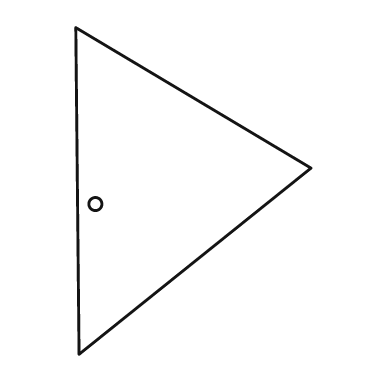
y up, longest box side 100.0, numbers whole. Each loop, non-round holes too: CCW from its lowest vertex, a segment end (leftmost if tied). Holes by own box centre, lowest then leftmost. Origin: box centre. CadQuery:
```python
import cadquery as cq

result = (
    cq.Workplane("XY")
    .moveTo(-35.0, -50.0)
    .lineTo(36.0, 7.0)
    .lineTo(-36.0, 50.0)
    .close()
    .moveTo(-30.0, -4.0)
    .circle(2.0)
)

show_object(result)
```